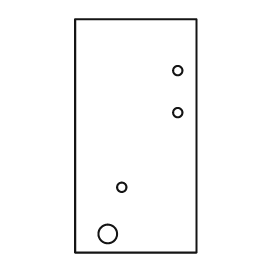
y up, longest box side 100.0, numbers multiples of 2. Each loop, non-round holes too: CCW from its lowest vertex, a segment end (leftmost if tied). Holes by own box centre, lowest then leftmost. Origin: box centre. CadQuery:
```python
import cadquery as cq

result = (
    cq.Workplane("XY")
    .moveTo(-26.0, -50.0)
    .lineTo(26.0, -50.0)
    .lineTo(26.0, 50.0)
    .lineTo(-26.0, 50.0)
    .close()
    .moveTo(-12.0, -42.0)
    .circle(4.0)
    .moveTo(-6.0, -22.0)
    .circle(2.0)
    .moveTo(18.0, 10.0)
    .circle(2.0)
    .moveTo(18.0, 28.0)
    .circle(2.0)
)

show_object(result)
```